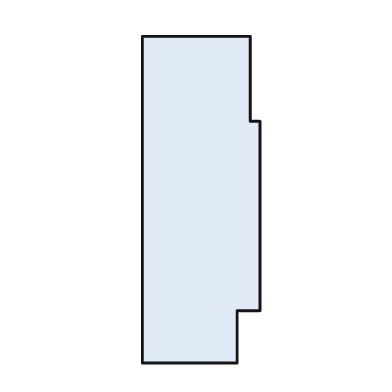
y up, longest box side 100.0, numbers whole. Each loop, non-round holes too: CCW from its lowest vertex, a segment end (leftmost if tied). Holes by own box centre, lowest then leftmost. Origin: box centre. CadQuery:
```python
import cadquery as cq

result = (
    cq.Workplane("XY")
    .moveTo(-18.0, -50.0)
    .lineTo(11.0, -50.0)
    .lineTo(11.0, -34.0)
    .lineTo(18.0, -34.0)
    .lineTo(18.0, 24.0)
    .lineTo(15.0, 24.0)
    .lineTo(15.0, 50.0)
    .lineTo(-18.0, 50.0)
    .close()
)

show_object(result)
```